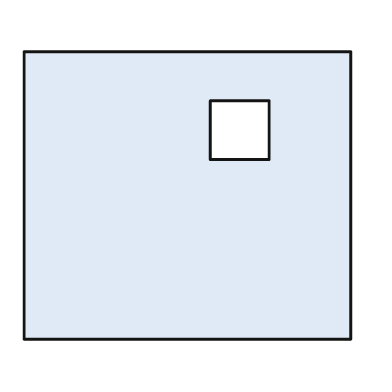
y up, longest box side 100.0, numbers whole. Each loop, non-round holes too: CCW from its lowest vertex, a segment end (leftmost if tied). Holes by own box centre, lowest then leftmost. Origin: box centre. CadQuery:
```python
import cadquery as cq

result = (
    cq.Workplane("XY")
    .moveTo(-50.0, -44.0)
    .lineTo(50.0, -44.0)
    .lineTo(50.0, 44.0)
    .lineTo(-50.0, 44.0)
    .close()
    .moveTo(7.0, 11.0)
    .lineTo(25.0, 11.0)
    .lineTo(25.0, 29.0)
    .lineTo(7.0, 29.0)
    .close()
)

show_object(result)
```